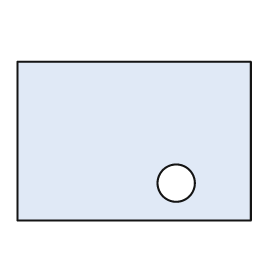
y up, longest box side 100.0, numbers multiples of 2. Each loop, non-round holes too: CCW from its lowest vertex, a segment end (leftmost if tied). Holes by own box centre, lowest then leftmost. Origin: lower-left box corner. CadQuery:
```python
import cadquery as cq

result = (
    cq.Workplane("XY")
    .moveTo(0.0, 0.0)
    .lineTo(100.0, 0.0)
    .lineTo(100.0, 68.0)
    .lineTo(0.0, 68.0)
    .close()
    .moveTo(68.0, 16.0)
    .circle(8.0)
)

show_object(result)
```